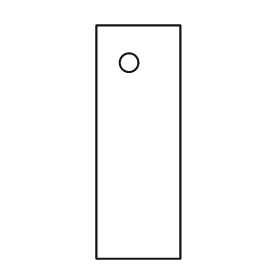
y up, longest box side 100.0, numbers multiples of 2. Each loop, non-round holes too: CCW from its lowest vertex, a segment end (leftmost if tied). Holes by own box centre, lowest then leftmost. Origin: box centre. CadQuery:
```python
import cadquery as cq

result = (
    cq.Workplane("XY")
    .moveTo(-18.0, -50.0)
    .lineTo(18.0, -50.0)
    .lineTo(18.0, 50.0)
    .lineTo(-18.0, 50.0)
    .close()
    .moveTo(-4.0, 34.0)
    .circle(4.0)
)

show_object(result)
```